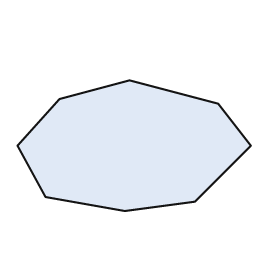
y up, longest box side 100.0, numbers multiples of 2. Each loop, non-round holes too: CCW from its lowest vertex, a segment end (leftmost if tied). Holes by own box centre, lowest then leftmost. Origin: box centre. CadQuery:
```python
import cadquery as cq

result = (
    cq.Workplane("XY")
    .moveTo(-4.0, -28.0)
    .lineTo(26.0, -24.0)
    .lineTo(50.0, 0.0)
    .lineTo(36.0, 18.0)
    .lineTo(-2.0, 28.0)
    .lineTo(-32.0, 20.0)
    .lineTo(-50.0, 0.0)
    .lineTo(-38.0, -22.0)
    .close()
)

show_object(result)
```